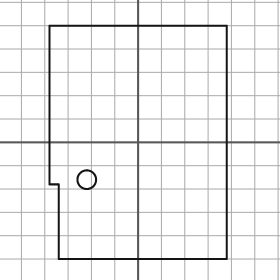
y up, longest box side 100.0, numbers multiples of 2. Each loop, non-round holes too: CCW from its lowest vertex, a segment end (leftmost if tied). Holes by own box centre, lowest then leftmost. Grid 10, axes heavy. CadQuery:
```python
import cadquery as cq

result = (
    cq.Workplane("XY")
    .moveTo(-34.0, -50.0)
    .lineTo(38.0, -50.0)
    .lineTo(38.0, 50.0)
    .lineTo(-38.0, 50.0)
    .lineTo(-38.0, -18.0)
    .lineTo(-34.0, -18.0)
    .close()
    .moveTo(-22.0, -16.0)
    .circle(4.0)
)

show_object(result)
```